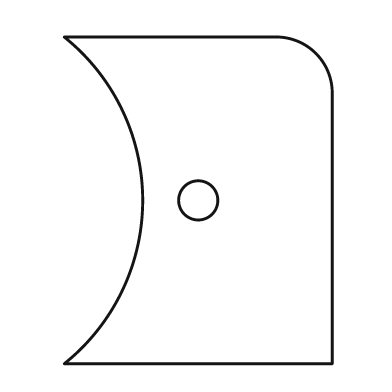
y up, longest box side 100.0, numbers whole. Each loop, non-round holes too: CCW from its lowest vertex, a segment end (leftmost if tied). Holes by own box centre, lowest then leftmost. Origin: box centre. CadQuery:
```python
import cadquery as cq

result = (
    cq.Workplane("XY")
    .moveTo(-41.0, -50.0)
    .lineTo(41.0, -50.0)
    .lineTo(41.0, 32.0)
    .threePointArc((36.0, 45.0), (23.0, 50.0))
    .lineTo(-41.0, 50.0)
    .threePointArc((-17.0, 0.0), (-41.0, -50.0))
    .close()
    .moveTo(0.0, 0.0)
    .circle(6.0)
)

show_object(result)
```